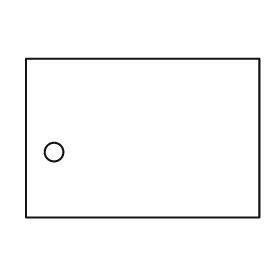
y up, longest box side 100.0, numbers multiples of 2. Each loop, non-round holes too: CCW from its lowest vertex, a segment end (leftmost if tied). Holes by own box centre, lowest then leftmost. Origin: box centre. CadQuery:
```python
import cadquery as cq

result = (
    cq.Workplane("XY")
    .moveTo(-50.0, -34.0)
    .lineTo(50.0, -34.0)
    .lineTo(50.0, 34.0)
    .lineTo(-50.0, 34.0)
    .close()
    .moveTo(-38.0, -6.0)
    .circle(4.0)
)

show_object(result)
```